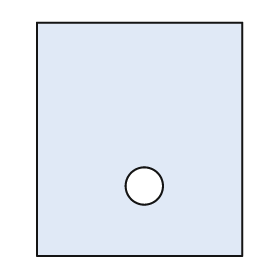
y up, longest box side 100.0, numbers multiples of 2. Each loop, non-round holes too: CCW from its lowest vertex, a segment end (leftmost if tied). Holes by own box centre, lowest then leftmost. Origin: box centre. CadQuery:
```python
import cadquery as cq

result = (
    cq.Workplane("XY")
    .moveTo(-44.0, -50.0)
    .lineTo(44.0, -50.0)
    .lineTo(44.0, 50.0)
    .lineTo(-44.0, 50.0)
    .close()
    .moveTo(2.0, -20.0)
    .circle(8.0)
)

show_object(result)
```